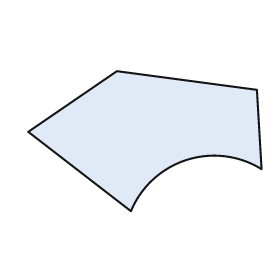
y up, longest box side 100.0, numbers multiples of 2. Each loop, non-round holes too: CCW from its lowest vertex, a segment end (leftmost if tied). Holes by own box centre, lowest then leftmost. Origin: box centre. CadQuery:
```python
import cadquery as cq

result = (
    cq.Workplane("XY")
    .moveTo(-6.0, -30.0)
    .threePointArc((18.0, -8.0), (50.0, -12.0))
    .lineTo(48.0, 22.0)
    .lineTo(-12.0, 30.0)
    .lineTo(-50.0, 4.0)
    .close()
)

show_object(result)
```